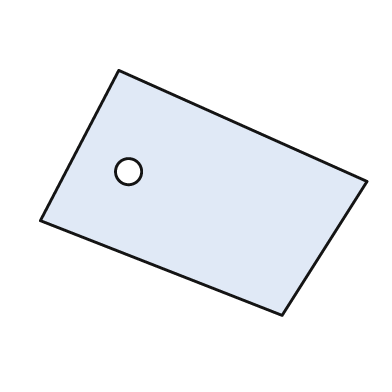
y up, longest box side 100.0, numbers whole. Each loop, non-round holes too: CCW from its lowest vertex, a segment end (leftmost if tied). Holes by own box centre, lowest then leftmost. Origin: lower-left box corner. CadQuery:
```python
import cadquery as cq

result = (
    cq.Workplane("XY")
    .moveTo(74.0, 0.0)
    .lineTo(100.0, 41.0)
    .lineTo(24.0, 75.0)
    .lineTo(0.0, 29.0)
    .close()
    .moveTo(27.0, 44.0)
    .circle(4.0)
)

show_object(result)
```